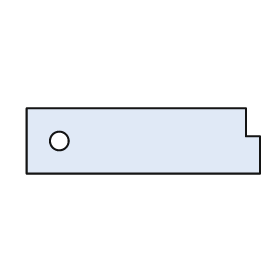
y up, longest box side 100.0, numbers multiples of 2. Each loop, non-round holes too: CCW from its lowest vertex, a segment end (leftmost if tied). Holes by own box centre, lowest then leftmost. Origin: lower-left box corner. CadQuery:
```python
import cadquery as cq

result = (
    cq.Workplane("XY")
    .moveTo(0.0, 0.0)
    .lineTo(100.0, 0.0)
    .lineTo(100.0, 16.0)
    .lineTo(94.0, 16.0)
    .lineTo(94.0, 28.0)
    .lineTo(0.0, 28.0)
    .close()
    .moveTo(14.0, 14.0)
    .circle(4.0)
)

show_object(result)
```